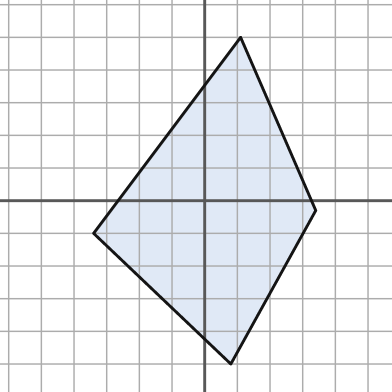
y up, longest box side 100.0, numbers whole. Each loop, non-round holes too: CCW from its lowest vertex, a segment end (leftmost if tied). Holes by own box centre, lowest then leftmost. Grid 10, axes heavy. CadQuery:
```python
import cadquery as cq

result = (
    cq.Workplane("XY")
    .moveTo(8.0, -50.0)
    .lineTo(34.0, -3.0)
    .lineTo(11.0, 50.0)
    .lineTo(-34.0, -10.0)
    .close()
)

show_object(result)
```